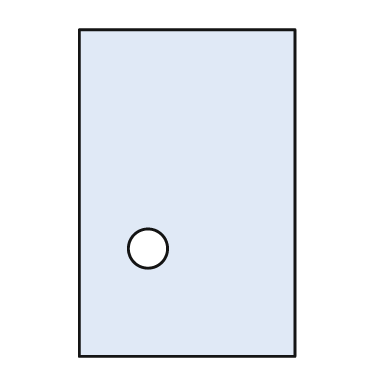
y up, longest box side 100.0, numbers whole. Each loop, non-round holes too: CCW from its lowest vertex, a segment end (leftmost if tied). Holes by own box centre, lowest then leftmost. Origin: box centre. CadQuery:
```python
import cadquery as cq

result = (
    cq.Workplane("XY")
    .moveTo(-33.0, -50.0)
    .lineTo(33.0, -50.0)
    .lineTo(33.0, 50.0)
    .lineTo(-33.0, 50.0)
    .close()
    .moveTo(-12.0, -17.0)
    .circle(6.0)
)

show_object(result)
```